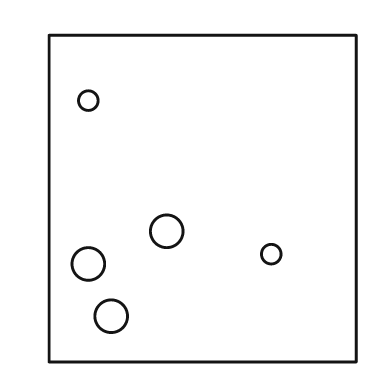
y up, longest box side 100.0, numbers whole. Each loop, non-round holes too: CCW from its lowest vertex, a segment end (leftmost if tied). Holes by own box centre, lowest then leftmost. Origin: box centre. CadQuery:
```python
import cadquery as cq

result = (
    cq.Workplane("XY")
    .moveTo(-47.0, -50.0)
    .lineTo(47.0, -50.0)
    .lineTo(47.0, 50.0)
    .lineTo(-47.0, 50.0)
    .close()
    .moveTo(-28.0, -36.0)
    .circle(5.0)
    .moveTo(-35.0, -20.0)
    .circle(5.0)
    .moveTo(21.0, -17.0)
    .circle(3.0)
    .moveTo(-11.0, -10.0)
    .circle(5.0)
    .moveTo(-35.0, 30.0)
    .circle(3.0)
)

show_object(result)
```